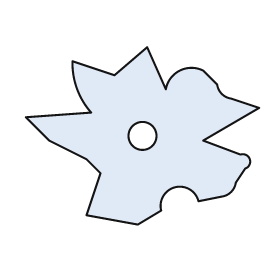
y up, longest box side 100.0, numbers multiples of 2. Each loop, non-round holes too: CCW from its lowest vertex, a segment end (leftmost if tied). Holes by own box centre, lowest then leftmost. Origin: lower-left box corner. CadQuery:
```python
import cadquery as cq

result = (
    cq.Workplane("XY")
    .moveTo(48.0, 0.0)
    .lineTo(58.0, 6.0)
    .threePointArc((64.0, 16.0), (74.0, 10.0))
    .lineTo(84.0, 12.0)
    .threePointArc((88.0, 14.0), (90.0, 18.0))
    .lineTo(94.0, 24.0)
    .threePointArc((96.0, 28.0), (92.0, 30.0))
    .lineTo(76.0, 36.0)
    .lineTo(100.0, 50.0)
    .lineTo(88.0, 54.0)
    .threePointArc((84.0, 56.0), (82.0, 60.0))
    .lineTo(76.0, 66.0)
    .threePointArc((66.0, 66.0), (60.0, 58.0))
    .lineTo(52.0, 76.0)
    .lineTo(38.0, 64.0)
    .lineTo(20.0, 70.0)
    .threePointArc((22.0, 58.0), (28.0, 48.0))
    .lineTo(0.0, 46.0)
    .lineTo(10.0, 36.0)
    .lineTo(26.0, 28.0)
    .lineTo(32.0, 22.0)
    .lineTo(26.0, 4.0)
    .close()
    .moveTo(50.0, 38.0)
    .circle(6.0)
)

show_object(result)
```